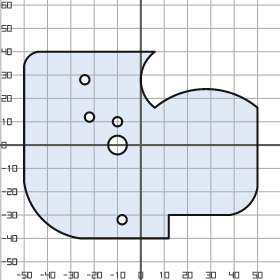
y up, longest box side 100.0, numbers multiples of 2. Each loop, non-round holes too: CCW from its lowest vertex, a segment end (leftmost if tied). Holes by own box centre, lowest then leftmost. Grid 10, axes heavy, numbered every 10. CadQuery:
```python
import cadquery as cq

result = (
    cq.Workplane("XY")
    .moveTo(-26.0, -40.0)
    .lineTo(12.0, -40.0)
    .lineTo(12.0, -30.0)
    .lineTo(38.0, -30.0)
    .threePointArc((46.0, -26.0), (50.0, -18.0))
    .lineTo(50.0, 16.0)
    .threePointArc((28.0, 24.0), (6.0, 16.0))
    .threePointArc((0.0, 28.0), (6.0, 40.0))
    .lineTo(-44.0, 40.0)
    .threePointArc((-48.0, 38.0), (-50.0, 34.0))
    .lineTo(-50.0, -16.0)
    .threePointArc((-42.0, -32.0), (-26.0, -40.0))
    .close()
    .moveTo(-8.0, -32.0)
    .circle(2.0)
    .moveTo(-10.0, 0.0)
    .circle(4.0)
    .moveTo(-10.0, 10.0)
    .circle(2.0)
    .moveTo(-22.0, 12.0)
    .circle(2.0)
    .moveTo(-24.0, 28.0)
    .circle(2.0)
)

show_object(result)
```